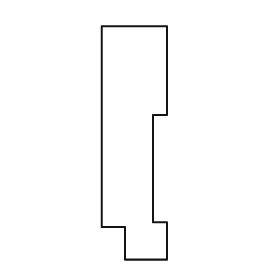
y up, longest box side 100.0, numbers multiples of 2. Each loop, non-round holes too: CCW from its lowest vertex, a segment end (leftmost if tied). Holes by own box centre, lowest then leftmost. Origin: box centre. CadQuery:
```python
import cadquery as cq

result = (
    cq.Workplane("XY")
    .moveTo(-4.0, -50.0)
    .lineTo(14.0, -50.0)
    .lineTo(14.0, -34.0)
    .lineTo(8.0, -34.0)
    .lineTo(8.0, 12.0)
    .lineTo(14.0, 12.0)
    .lineTo(14.0, 50.0)
    .lineTo(-14.0, 50.0)
    .lineTo(-14.0, -36.0)
    .lineTo(-4.0, -36.0)
    .close()
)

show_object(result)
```